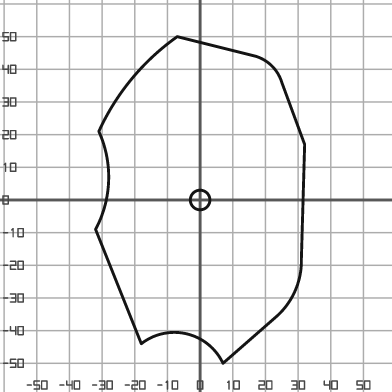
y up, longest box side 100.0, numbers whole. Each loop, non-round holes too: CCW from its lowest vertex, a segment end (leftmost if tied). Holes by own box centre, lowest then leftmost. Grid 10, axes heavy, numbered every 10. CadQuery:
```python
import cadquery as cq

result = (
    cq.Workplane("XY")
    .moveTo(7.0, -50.0)
    .lineTo(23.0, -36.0)
    .threePointArc((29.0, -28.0), (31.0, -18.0))
    .lineTo(32.0, 17.0)
    .lineTo(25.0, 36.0)
    .threePointArc((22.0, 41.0), (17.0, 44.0))
    .lineTo(-7.0, 50.0)
    .threePointArc((-21.0, 37.0), (-31.0, 21.0))
    .threePointArc((-28.0, 6.0), (-32.0, -9.0))
    .lineTo(-18.0, -44.0)
    .threePointArc((-4.0, -41.0), (7.0, -50.0))
    .close()
    .moveTo(0.0, 0.0)
    .circle(3.0)
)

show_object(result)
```